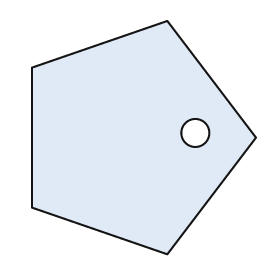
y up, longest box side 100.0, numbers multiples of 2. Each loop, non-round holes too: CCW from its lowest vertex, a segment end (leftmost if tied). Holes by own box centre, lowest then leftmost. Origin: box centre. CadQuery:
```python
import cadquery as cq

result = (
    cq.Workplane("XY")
    .moveTo(10.0, -50.0)
    .lineTo(48.0, 0.0)
    .lineTo(10.0, 50.0)
    .lineTo(-48.0, 30.0)
    .lineTo(-48.0, -30.0)
    .close()
    .moveTo(22.0, 2.0)
    .circle(6.0)
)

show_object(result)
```